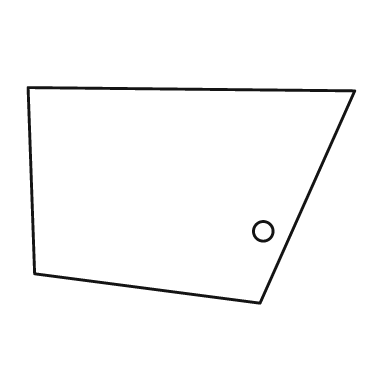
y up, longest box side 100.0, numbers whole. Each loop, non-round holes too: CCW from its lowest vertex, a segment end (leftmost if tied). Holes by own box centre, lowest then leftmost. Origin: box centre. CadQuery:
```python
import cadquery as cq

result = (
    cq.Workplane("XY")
    .moveTo(21.0, -33.0)
    .lineTo(50.0, 32.0)
    .lineTo(-50.0, 33.0)
    .lineTo(-48.0, -24.0)
    .close()
    .moveTo(22.0, -11.0)
    .circle(3.0)
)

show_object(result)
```